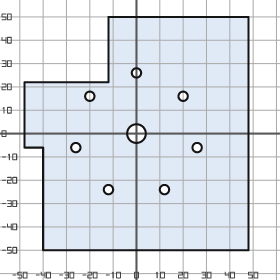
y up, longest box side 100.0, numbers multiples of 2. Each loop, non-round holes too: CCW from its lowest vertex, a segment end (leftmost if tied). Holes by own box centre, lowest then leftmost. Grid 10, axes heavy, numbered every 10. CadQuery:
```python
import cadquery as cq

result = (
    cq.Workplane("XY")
    .moveTo(-40.0, -50.0)
    .lineTo(48.0, -50.0)
    .lineTo(48.0, 50.0)
    .lineTo(-12.0, 50.0)
    .lineTo(-12.0, 22.0)
    .lineTo(-48.0, 22.0)
    .lineTo(-48.0, -6.0)
    .lineTo(-40.0, -6.0)
    .close()
    .moveTo(-12.0, -24.0)
    .circle(2.0)
    .moveTo(12.0, -24.0)
    .circle(2.0)
    .moveTo(-26.0, -6.0)
    .circle(2.0)
    .moveTo(26.0, -6.0)
    .circle(2.0)
    .moveTo(0.0, 0.0)
    .circle(4.0)
    .moveTo(-20.0, 16.0)
    .circle(2.0)
    .moveTo(20.0, 16.0)
    .circle(2.0)
    .moveTo(0.0, 26.0)
    .circle(2.0)
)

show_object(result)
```